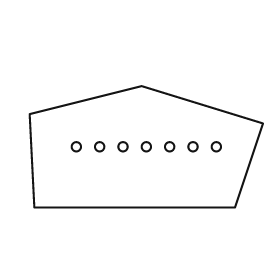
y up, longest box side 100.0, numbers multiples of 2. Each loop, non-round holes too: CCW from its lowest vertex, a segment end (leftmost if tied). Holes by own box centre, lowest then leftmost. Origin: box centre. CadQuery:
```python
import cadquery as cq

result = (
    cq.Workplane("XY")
    .moveTo(-48.0, -26.0)
    .lineTo(38.0, -26.0)
    .lineTo(50.0, 10.0)
    .lineTo(-2.0, 26.0)
    .lineTo(-50.0, 14.0)
    .close()
    .moveTo(-30.0, 0.0)
    .circle(2.0)
    .moveTo(-20.0, 0.0)
    .circle(2.0)
    .moveTo(-10.0, 0.0)
    .circle(2.0)
    .moveTo(0.0, 0.0)
    .circle(2.0)
    .moveTo(10.0, 0.0)
    .circle(2.0)
    .moveTo(20.0, 0.0)
    .circle(2.0)
    .moveTo(30.0, 0.0)
    .circle(2.0)
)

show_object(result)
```